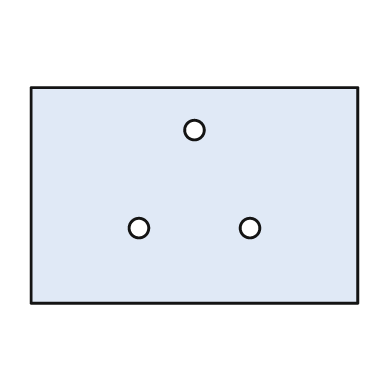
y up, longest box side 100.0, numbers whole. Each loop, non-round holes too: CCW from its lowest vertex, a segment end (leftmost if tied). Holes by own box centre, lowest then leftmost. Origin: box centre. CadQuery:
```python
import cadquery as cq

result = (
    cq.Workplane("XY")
    .moveTo(-50.0, -33.0)
    .lineTo(50.0, -33.0)
    .lineTo(50.0, 33.0)
    .lineTo(-50.0, 33.0)
    .close()
    .moveTo(-17.0, -10.0)
    .circle(3.0)
    .moveTo(17.0, -10.0)
    .circle(3.0)
    .moveTo(0.0, 20.0)
    .circle(3.0)
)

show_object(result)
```